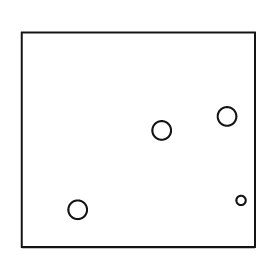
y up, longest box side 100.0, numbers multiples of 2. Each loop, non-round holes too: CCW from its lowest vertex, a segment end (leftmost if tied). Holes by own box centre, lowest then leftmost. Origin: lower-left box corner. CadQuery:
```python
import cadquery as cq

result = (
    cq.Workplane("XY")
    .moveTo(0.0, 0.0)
    .lineTo(100.0, 0.0)
    .lineTo(100.0, 92.0)
    .lineTo(0.0, 92.0)
    .close()
    .moveTo(24.0, 16.0)
    .circle(4.0)
    .moveTo(94.0, 20.0)
    .circle(2.0)
    .moveTo(60.0, 50.0)
    .circle(4.0)
    .moveTo(88.0, 56.0)
    .circle(4.0)
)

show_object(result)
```